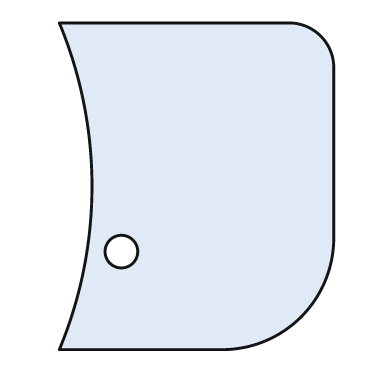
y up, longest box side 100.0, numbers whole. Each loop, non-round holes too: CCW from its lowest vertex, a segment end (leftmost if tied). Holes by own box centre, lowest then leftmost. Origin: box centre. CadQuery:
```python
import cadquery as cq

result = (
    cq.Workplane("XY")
    .moveTo(-42.0, -50.0)
    .lineTo(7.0, -50.0)
    .threePointArc((32.0, -40.0), (42.0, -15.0))
    .lineTo(42.0, 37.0)
    .threePointArc((38.0, 46.0), (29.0, 50.0))
    .lineTo(-42.0, 50.0)
    .threePointArc((-32.0, 0.0), (-42.0, -50.0))
    .close()
    .moveTo(-23.0, -20.0)
    .circle(5.0)
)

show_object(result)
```